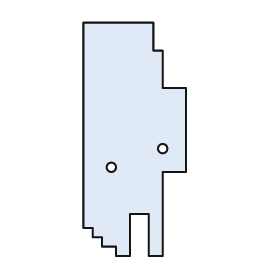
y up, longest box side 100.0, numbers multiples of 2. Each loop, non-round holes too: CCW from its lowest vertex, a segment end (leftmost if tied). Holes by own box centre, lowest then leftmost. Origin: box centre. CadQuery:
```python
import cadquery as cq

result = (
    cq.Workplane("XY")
    .moveTo(-8.0, -50.0)
    .lineTo(-2.0, -50.0)
    .lineTo(-2.0, -32.0)
    .lineTo(6.0, -32.0)
    .lineTo(6.0, -50.0)
    .lineTo(12.0, -50.0)
    .lineTo(12.0, -14.0)
    .lineTo(22.0, -14.0)
    .lineTo(22.0, 22.0)
    .lineTo(12.0, 22.0)
    .lineTo(12.0, 38.0)
    .lineTo(8.0, 38.0)
    .lineTo(8.0, 50.0)
    .lineTo(-22.0, 50.0)
    .lineTo(-22.0, -38.0)
    .lineTo(-18.0, -38.0)
    .lineTo(-18.0, -42.0)
    .lineTo(-14.0, -42.0)
    .lineTo(-14.0, -46.0)
    .lineTo(-8.0, -46.0)
    .close()
    .moveTo(-10.0, -12.0)
    .circle(2.0)
    .moveTo(12.0, -4.0)
    .circle(2.0)
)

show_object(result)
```